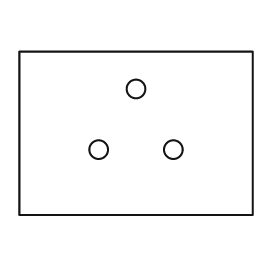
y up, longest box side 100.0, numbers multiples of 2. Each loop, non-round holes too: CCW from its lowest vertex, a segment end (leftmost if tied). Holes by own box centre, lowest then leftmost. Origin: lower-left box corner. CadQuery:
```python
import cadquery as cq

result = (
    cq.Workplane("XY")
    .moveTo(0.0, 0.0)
    .lineTo(100.0, 0.0)
    .lineTo(100.0, 70.0)
    .lineTo(0.0, 70.0)
    .close()
    .moveTo(34.0, 28.0)
    .circle(4.0)
    .moveTo(66.0, 28.0)
    .circle(4.0)
    .moveTo(50.0, 54.0)
    .circle(4.0)
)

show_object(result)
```